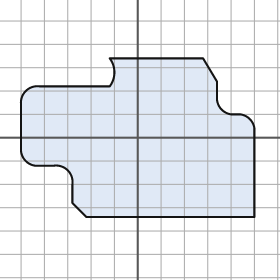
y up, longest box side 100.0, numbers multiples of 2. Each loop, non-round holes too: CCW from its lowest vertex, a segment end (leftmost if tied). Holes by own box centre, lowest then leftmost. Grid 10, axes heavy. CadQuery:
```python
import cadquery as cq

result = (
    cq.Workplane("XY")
    .moveTo(-22.0, -34.0)
    .lineTo(50.0, -34.0)
    .lineTo(50.0, 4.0)
    .threePointArc((48.0, 8.0), (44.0, 10.0))
    .lineTo(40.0, 10.0)
    .threePointArc((36.0, 12.0), (34.0, 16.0))
    .lineTo(34.0, 24.0)
    .lineTo(28.0, 34.0)
    .lineTo(-12.0, 34.0)
    .threePointArc((-10.0, 28.0), (-12.0, 22.0))
    .lineTo(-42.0, 22.0)
    .threePointArc((-48.0, 20.0), (-50.0, 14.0))
    .lineTo(-50.0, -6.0)
    .threePointArc((-48.0, -10.0), (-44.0, -12.0))
    .lineTo(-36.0, -12.0)
    .threePointArc((-30.0, -14.0), (-28.0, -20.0))
    .lineTo(-28.0, -28.0)
    .close()
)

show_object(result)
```